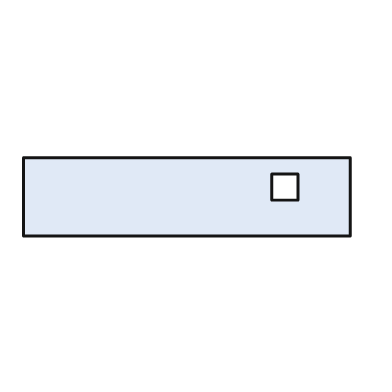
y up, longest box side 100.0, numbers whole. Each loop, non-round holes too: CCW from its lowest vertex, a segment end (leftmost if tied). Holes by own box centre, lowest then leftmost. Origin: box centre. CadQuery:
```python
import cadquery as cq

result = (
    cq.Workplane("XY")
    .moveTo(-50.0, -12.0)
    .lineTo(50.0, -12.0)
    .lineTo(50.0, 12.0)
    .lineTo(-50.0, 12.0)
    .close()
    .moveTo(26.0, -1.0)
    .lineTo(34.0, -1.0)
    .lineTo(34.0, 7.0)
    .lineTo(26.0, 7.0)
    .close()
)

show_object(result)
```